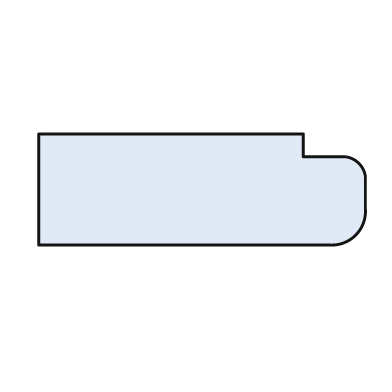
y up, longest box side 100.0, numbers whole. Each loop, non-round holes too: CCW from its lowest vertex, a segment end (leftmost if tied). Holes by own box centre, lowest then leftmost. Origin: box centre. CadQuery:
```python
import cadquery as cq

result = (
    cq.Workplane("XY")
    .moveTo(-50.0, -17.0)
    .lineTo(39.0, -17.0)
    .threePointArc((47.0, -14.0), (50.0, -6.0))
    .lineTo(50.0, 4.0)
    .threePointArc((48.0, 8.0), (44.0, 10.0))
    .lineTo(31.0, 10.0)
    .lineTo(31.0, 17.0)
    .lineTo(-50.0, 17.0)
    .close()
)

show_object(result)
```